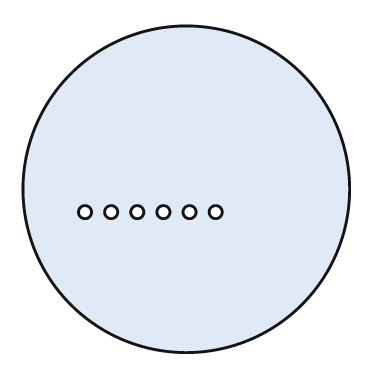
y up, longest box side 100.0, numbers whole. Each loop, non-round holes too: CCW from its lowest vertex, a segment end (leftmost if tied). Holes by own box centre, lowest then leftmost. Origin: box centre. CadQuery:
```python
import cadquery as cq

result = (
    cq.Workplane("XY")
    .moveTo(0.0, 0.0)
    .circle(50.0)
    .moveTo(-31.0, -7.0)
    .circle(2.0)
    .moveTo(-23.0, -7.0)
    .circle(2.0)
    .moveTo(-15.0, -7.0)
    .circle(2.0)
    .moveTo(-7.0, -7.0)
    .circle(2.0)
    .moveTo(1.0, -7.0)
    .circle(2.0)
    .moveTo(9.0, -7.0)
    .circle(2.0)
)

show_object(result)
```